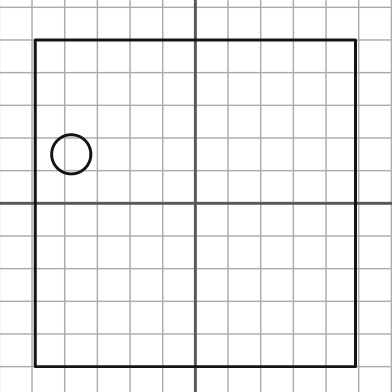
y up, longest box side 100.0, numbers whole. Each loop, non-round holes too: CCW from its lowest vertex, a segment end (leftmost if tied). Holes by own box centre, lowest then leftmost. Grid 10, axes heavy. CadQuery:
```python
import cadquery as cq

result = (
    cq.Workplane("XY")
    .moveTo(-49.0, -50.0)
    .lineTo(49.0, -50.0)
    .lineTo(49.0, 50.0)
    .lineTo(-49.0, 50.0)
    .close()
    .moveTo(-38.0, 15.0)
    .circle(6.0)
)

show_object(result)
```